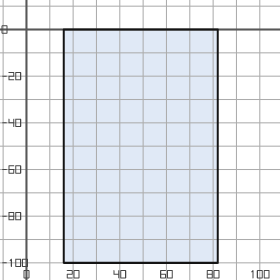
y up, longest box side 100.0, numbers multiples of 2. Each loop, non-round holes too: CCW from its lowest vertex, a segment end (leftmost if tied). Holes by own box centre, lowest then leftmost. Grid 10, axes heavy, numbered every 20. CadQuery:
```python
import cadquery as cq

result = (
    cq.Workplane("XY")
    .moveTo(16.0, -100.0)
    .lineTo(82.0, -100.0)
    .lineTo(82.0, 0.0)
    .lineTo(16.0, 0.0)
    .close()
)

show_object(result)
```